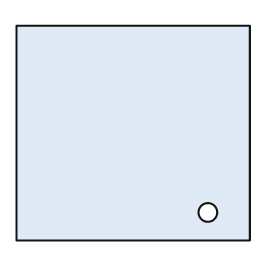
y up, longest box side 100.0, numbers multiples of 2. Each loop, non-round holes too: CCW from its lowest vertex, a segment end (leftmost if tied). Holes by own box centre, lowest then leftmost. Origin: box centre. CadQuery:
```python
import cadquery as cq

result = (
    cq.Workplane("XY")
    .moveTo(-50.0, -46.0)
    .lineTo(50.0, -46.0)
    .lineTo(50.0, 46.0)
    .lineTo(-50.0, 46.0)
    .close()
    .moveTo(32.0, -34.0)
    .circle(4.0)
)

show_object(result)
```